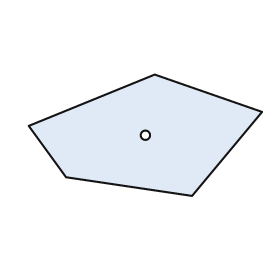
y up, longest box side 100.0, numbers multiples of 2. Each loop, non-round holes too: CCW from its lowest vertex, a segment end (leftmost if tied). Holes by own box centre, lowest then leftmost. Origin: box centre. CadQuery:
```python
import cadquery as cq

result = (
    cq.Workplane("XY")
    .moveTo(20.0, -26.0)
    .lineTo(50.0, 10.0)
    .lineTo(4.0, 26.0)
    .lineTo(-50.0, 4.0)
    .lineTo(-34.0, -18.0)
    .close()
    .moveTo(0.0, 0.0)
    .circle(2.0)
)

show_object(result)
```